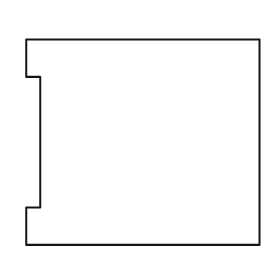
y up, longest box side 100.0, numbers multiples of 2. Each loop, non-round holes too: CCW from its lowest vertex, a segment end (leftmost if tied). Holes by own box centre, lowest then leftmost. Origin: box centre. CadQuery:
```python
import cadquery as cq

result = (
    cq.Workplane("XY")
    .moveTo(-50.0, -44.0)
    .lineTo(50.0, -44.0)
    .lineTo(50.0, 44.0)
    .lineTo(-50.0, 44.0)
    .lineTo(-50.0, 28.0)
    .lineTo(-44.0, 28.0)
    .lineTo(-44.0, -28.0)
    .lineTo(-50.0, -28.0)
    .close()
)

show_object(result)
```